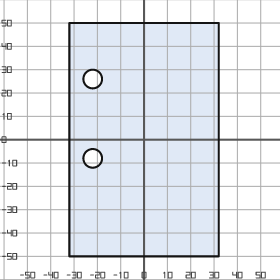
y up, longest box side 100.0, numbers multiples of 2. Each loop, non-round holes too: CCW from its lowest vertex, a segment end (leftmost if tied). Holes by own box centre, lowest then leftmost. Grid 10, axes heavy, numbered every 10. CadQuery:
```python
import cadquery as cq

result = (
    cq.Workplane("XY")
    .moveTo(-32.0, -50.0)
    .lineTo(32.0, -50.0)
    .lineTo(32.0, 50.0)
    .lineTo(-32.0, 50.0)
    .close()
    .moveTo(-22.0, -8.0)
    .circle(4.0)
    .moveTo(-22.0, 26.0)
    .circle(4.0)
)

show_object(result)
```